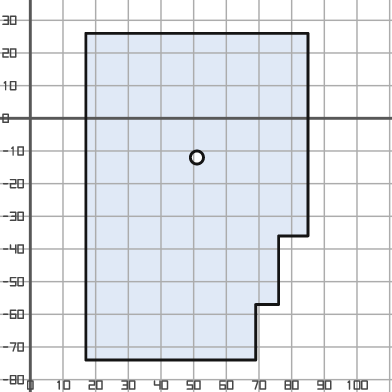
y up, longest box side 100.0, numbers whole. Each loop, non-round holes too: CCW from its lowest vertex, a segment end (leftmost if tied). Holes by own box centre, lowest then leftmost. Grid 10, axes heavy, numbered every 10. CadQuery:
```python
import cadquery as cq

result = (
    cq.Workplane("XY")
    .moveTo(17.0, -74.0)
    .lineTo(69.0, -74.0)
    .lineTo(69.0, -57.0)
    .lineTo(76.0, -57.0)
    .lineTo(76.0, -36.0)
    .lineTo(85.0, -36.0)
    .lineTo(85.0, 26.0)
    .lineTo(17.0, 26.0)
    .close()
    .moveTo(51.0, -12.0)
    .circle(2.0)
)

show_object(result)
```